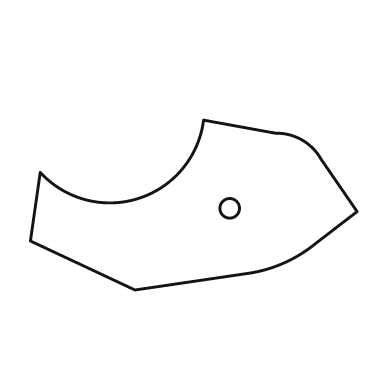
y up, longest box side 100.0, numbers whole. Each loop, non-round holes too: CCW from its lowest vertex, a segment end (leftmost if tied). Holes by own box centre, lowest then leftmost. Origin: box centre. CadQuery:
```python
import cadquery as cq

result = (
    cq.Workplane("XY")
    .moveTo(-18.0, -26.0)
    .lineTo(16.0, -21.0)
    .threePointArc((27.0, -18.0), (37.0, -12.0))
    .lineTo(50.0, -2.0)
    .lineTo(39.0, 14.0)
    .threePointArc((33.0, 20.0), (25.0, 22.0))
    .lineTo(3.0, 26.0)
    .threePointArc((-17.0, 2.0), (-47.0, 10.0))
    .lineTo(-50.0, -11.0)
    .close()
    .moveTo(11.0, -1.0)
    .circle(3.0)
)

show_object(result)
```